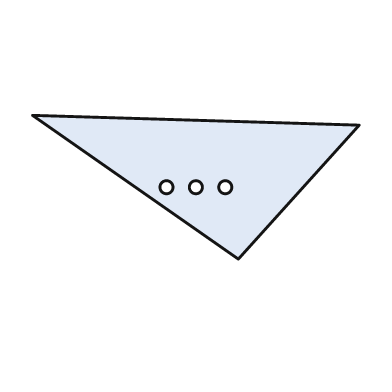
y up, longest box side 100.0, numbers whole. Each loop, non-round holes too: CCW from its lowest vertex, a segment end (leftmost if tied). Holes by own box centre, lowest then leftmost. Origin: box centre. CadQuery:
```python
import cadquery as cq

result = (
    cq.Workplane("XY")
    .moveTo(13.0, -22.0)
    .lineTo(50.0, 19.0)
    .lineTo(-50.0, 22.0)
    .close()
    .moveTo(-9.0, 0.0)
    .circle(2.0)
    .moveTo(0.0, 0.0)
    .circle(2.0)
    .moveTo(9.0, 0.0)
    .circle(2.0)
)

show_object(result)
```